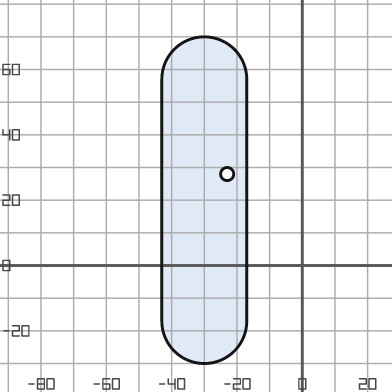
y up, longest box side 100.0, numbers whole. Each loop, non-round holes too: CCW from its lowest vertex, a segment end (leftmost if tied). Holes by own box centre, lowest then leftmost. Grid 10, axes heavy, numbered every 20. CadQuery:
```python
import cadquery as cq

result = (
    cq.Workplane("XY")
    .moveTo(-43.0, -17.0)
    .threePointArc((-30.0, -30.0), (-17.0, -17.0))
    .lineTo(-17.0, 57.0)
    .threePointArc((-30.0, 70.0), (-43.0, 57.0))
    .close()
    .moveTo(-23.0, 28.0)
    .circle(2.0)
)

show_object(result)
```